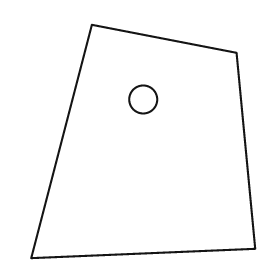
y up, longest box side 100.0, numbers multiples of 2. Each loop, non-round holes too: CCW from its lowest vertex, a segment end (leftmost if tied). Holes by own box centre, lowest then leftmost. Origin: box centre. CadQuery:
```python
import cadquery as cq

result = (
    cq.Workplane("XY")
    .moveTo(-48.0, -50.0)
    .lineTo(48.0, -46.0)
    .lineTo(40.0, 38.0)
    .lineTo(-22.0, 50.0)
    .close()
    .moveTo(0.0, 18.0)
    .circle(6.0)
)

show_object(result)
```